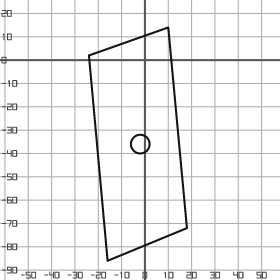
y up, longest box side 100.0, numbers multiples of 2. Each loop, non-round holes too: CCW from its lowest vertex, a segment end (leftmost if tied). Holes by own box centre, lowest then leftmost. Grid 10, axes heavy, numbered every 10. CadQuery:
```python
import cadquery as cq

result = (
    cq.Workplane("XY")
    .moveTo(-16.0, -86.0)
    .lineTo(18.0, -72.0)
    .lineTo(10.0, 14.0)
    .lineTo(-24.0, 2.0)
    .close()
    .moveTo(-2.0, -36.0)
    .circle(4.0)
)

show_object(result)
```